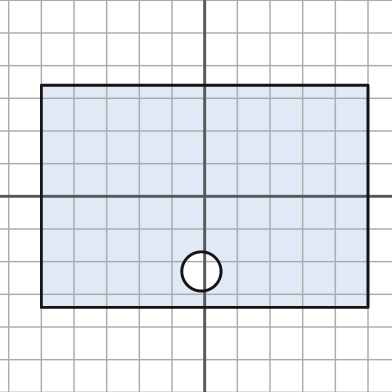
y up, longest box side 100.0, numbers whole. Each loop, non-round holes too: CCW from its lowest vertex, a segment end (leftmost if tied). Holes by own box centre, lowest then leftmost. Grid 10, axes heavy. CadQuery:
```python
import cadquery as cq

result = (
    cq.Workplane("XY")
    .moveTo(-50.0, -34.0)
    .lineTo(50.0, -34.0)
    .lineTo(50.0, 34.0)
    .lineTo(-50.0, 34.0)
    .close()
    .moveTo(-1.0, -23.0)
    .circle(6.0)
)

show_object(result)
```